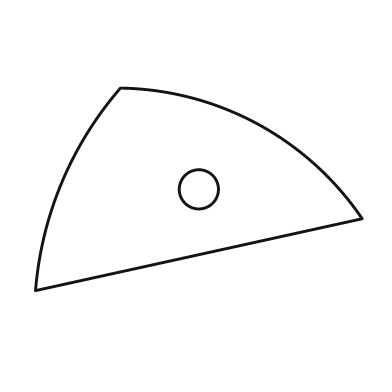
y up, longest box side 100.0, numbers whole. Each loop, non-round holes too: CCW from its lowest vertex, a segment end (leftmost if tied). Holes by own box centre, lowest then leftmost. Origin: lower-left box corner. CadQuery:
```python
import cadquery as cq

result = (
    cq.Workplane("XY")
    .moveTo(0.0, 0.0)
    .lineTo(100.0, 22.0)
    .threePointArc((68.0, 51.0), (26.0, 62.0))
    .threePointArc((8.0, 33.0), (0.0, 0.0))
    .close()
    .moveTo(50.0, 31.0)
    .circle(6.0)
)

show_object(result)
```